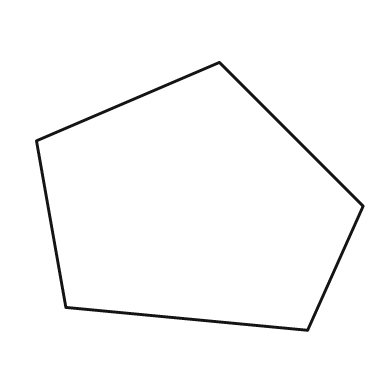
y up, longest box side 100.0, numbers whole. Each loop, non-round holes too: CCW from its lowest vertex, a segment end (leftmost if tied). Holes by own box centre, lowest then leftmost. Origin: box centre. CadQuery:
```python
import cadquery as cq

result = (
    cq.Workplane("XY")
    .moveTo(33.0, -41.0)
    .lineTo(50.0, -3.0)
    .lineTo(6.0, 41.0)
    .lineTo(-50.0, 17.0)
    .lineTo(-41.0, -34.0)
    .close()
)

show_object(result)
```